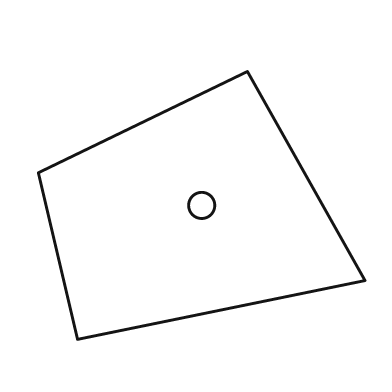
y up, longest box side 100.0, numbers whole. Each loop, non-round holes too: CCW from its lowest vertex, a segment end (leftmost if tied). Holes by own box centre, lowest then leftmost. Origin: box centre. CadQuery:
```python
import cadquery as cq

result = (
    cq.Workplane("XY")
    .moveTo(-38.0, -41.0)
    .lineTo(50.0, -23.0)
    .lineTo(14.0, 41.0)
    .lineTo(-50.0, 10.0)
    .close()
    .moveTo(0.0, 0.0)
    .circle(4.0)
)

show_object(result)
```